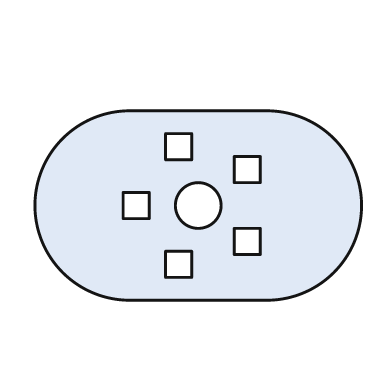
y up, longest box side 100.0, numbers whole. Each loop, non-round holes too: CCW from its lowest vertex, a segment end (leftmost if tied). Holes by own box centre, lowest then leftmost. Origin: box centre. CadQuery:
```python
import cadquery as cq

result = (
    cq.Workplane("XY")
    .moveTo(-21.0, -29.0)
    .lineTo(21.0, -29.0)
    .threePointArc((50.0, 0.0), (21.0, 29.0))
    .lineTo(-21.0, 29.0)
    .threePointArc((-50.0, 0.0), (-21.0, -29.0))
    .close()
    .moveTo(-10.0, -22.0)
    .lineTo(-2.0, -22.0)
    .lineTo(-2.0, -14.0)
    .lineTo(-10.0, -14.0)
    .close()
    .moveTo(11.0, -15.0)
    .lineTo(19.0, -15.0)
    .lineTo(19.0, -7.0)
    .lineTo(11.0, -7.0)
    .close()
    .moveTo(-23.0, -4.0)
    .lineTo(-15.0, -4.0)
    .lineTo(-15.0, 4.0)
    .lineTo(-23.0, 4.0)
    .close()
    .moveTo(0.0, 0.0)
    .circle(7.0)
    .moveTo(11.0, 7.0)
    .lineTo(19.0, 7.0)
    .lineTo(19.0, 15.0)
    .lineTo(11.0, 15.0)
    .close()
    .moveTo(-10.0, 14.0)
    .lineTo(-2.0, 14.0)
    .lineTo(-2.0, 22.0)
    .lineTo(-10.0, 22.0)
    .close()
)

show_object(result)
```